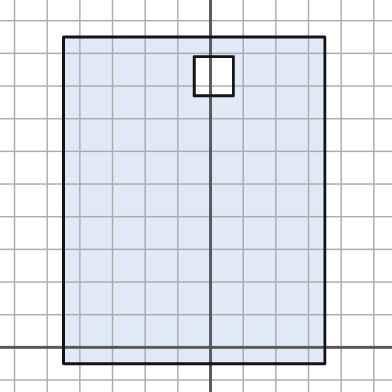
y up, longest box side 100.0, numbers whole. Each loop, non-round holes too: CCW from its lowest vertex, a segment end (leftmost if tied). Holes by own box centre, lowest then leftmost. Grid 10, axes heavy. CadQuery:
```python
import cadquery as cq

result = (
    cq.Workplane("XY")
    .moveTo(-45.0, -5.0)
    .lineTo(35.0, -5.0)
    .lineTo(35.0, 95.0)
    .lineTo(-45.0, 95.0)
    .close()
    .moveTo(-5.0, 77.0)
    .lineTo(7.0, 77.0)
    .lineTo(7.0, 89.0)
    .lineTo(-5.0, 89.0)
    .close()
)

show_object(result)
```